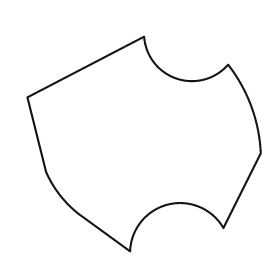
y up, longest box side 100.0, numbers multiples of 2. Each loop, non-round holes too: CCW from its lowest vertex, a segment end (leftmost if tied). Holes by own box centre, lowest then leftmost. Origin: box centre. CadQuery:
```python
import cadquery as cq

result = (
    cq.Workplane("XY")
    .moveTo(-6.0, -46.0)
    .threePointArc((10.0, -26.0), (34.0, -36.0))
    .lineTo(50.0, -4.0)
    .threePointArc((46.0, 16.0), (36.0, 34.0))
    .threePointArc((14.0, 28.0), (0.0, 46.0))
    .lineTo(-50.0, 20.0)
    .lineTo(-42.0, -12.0)
    .threePointArc((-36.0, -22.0), (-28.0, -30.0))
    .close()
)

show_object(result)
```